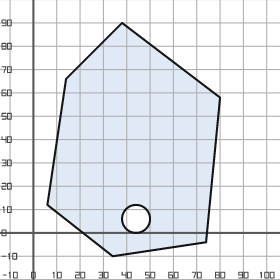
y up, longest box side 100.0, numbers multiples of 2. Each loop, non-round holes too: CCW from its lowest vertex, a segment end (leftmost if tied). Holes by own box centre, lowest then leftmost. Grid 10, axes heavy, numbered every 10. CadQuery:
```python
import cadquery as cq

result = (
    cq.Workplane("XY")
    .moveTo(34.0, -10.0)
    .lineTo(74.0, -4.0)
    .lineTo(80.0, 58.0)
    .lineTo(38.0, 90.0)
    .lineTo(14.0, 66.0)
    .lineTo(6.0, 12.0)
    .close()
    .moveTo(44.0, 6.0)
    .circle(6.0)
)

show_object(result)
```